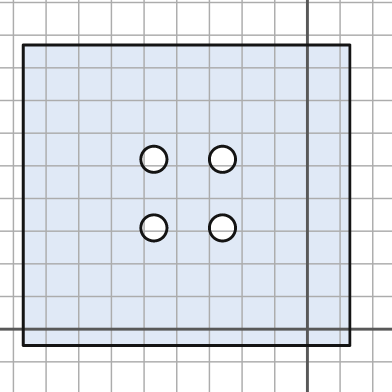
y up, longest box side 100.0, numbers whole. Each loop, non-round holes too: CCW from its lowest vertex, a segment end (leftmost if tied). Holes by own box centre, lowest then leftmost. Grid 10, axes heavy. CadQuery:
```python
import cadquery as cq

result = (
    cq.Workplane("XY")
    .moveTo(-87.0, -5.0)
    .lineTo(13.0, -5.0)
    .lineTo(13.0, 87.0)
    .lineTo(-87.0, 87.0)
    .close()
    .moveTo(-47.0, 31.0)
    .circle(4.0)
    .moveTo(-26.0, 31.0)
    .circle(4.0)
    .moveTo(-47.0, 52.0)
    .circle(4.0)
    .moveTo(-26.0, 52.0)
    .circle(4.0)
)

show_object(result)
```